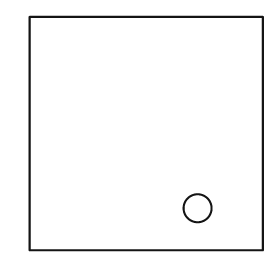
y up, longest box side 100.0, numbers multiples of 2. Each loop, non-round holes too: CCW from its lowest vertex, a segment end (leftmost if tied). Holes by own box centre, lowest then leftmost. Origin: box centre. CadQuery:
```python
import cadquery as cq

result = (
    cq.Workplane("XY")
    .moveTo(-50.0, -50.0)
    .lineTo(50.0, -50.0)
    .lineTo(50.0, 50.0)
    .lineTo(-50.0, 50.0)
    .close()
    .moveTo(22.0, -32.0)
    .circle(6.0)
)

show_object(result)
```